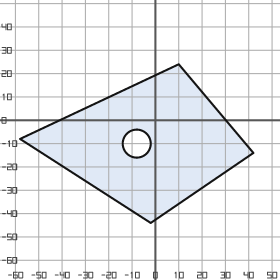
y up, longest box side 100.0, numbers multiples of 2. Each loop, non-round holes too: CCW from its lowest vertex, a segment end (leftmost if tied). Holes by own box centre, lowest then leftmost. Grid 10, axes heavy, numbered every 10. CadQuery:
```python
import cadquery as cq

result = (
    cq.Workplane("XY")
    .moveTo(-2.0, -44.0)
    .lineTo(42.0, -14.0)
    .lineTo(10.0, 24.0)
    .lineTo(-58.0, -8.0)
    .close()
    .moveTo(-8.0, -10.0)
    .circle(6.0)
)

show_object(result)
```